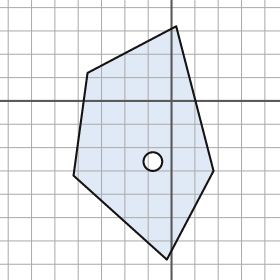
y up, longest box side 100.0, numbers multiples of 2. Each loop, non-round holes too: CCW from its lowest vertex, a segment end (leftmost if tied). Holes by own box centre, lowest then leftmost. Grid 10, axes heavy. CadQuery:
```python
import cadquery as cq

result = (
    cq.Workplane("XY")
    .moveTo(-2.0, -68.0)
    .lineTo(18.0, -30.0)
    .lineTo(2.0, 32.0)
    .lineTo(-36.0, 12.0)
    .lineTo(-42.0, -32.0)
    .close()
    .moveTo(-8.0, -26.0)
    .circle(4.0)
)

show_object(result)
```